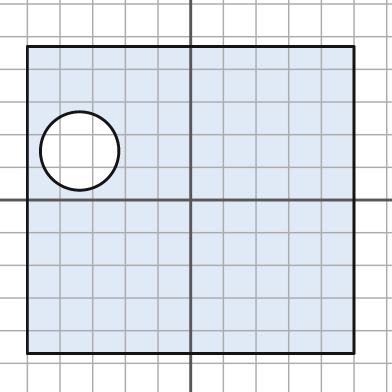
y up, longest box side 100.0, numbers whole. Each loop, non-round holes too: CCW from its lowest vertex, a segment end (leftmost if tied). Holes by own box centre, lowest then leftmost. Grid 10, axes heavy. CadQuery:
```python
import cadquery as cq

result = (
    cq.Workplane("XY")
    .moveTo(-50.0, -47.0)
    .lineTo(50.0, -47.0)
    .lineTo(50.0, 47.0)
    .lineTo(-50.0, 47.0)
    .close()
    .moveTo(-34.0, 15.0)
    .circle(12.0)
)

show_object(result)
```